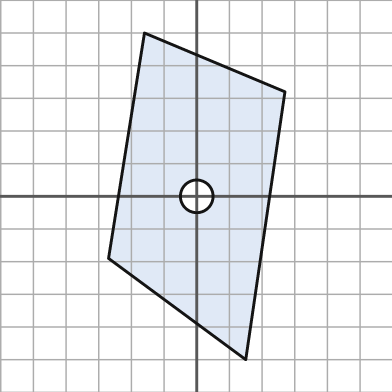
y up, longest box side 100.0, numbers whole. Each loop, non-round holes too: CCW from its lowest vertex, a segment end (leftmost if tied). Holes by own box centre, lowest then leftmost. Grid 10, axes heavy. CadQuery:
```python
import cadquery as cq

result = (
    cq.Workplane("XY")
    .moveTo(15.0, -50.0)
    .lineTo(27.0, 32.0)
    .lineTo(-16.0, 50.0)
    .lineTo(-27.0, -19.0)
    .close()
    .moveTo(0.0, 0.0)
    .circle(5.0)
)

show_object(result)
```